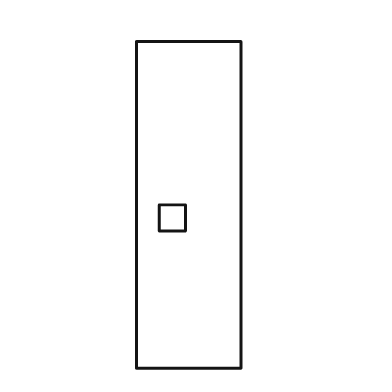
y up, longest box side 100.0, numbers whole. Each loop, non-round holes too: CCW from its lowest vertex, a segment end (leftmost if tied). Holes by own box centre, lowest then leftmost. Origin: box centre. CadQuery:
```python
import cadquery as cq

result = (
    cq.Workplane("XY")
    .moveTo(-16.0, -50.0)
    .lineTo(16.0, -50.0)
    .lineTo(16.0, 50.0)
    .lineTo(-16.0, 50.0)
    .close()
    .moveTo(-9.0, -8.0)
    .lineTo(-1.0, -8.0)
    .lineTo(-1.0, 0.0)
    .lineTo(-9.0, 0.0)
    .close()
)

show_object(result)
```